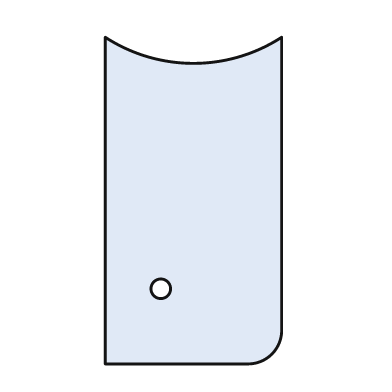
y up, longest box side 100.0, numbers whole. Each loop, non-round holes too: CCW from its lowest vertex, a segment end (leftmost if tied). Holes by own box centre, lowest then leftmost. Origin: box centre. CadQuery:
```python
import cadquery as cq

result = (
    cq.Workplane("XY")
    .moveTo(-27.0, -50.0)
    .lineTo(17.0, -50.0)
    .threePointArc((24.0, -47.0), (27.0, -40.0))
    .lineTo(27.0, 50.0)
    .threePointArc((0.0, 42.0), (-27.0, 50.0))
    .close()
    .moveTo(-10.0, -27.0)
    .circle(3.0)
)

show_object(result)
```